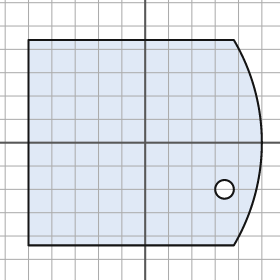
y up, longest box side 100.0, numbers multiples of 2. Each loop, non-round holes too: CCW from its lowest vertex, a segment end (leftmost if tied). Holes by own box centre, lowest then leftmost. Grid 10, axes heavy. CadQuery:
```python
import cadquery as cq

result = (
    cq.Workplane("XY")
    .moveTo(-50.0, -44.0)
    .lineTo(38.0, -44.0)
    .threePointArc((50.0, 0.0), (38.0, 44.0))
    .lineTo(-50.0, 44.0)
    .close()
    .moveTo(34.0, -20.0)
    .circle(4.0)
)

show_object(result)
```